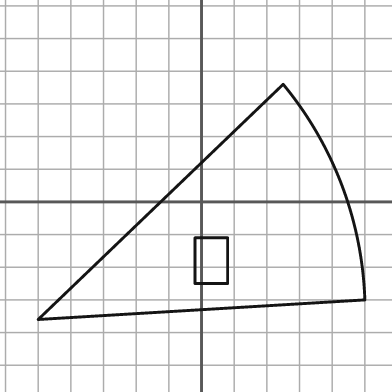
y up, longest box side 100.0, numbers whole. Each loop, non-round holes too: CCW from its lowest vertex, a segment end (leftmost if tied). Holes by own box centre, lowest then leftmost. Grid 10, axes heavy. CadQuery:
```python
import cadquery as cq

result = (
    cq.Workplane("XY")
    .moveTo(-50.0, -36.0)
    .lineTo(50.0, -30.0)
    .threePointArc((43.0, 5.0), (25.0, 36.0))
    .close()
    .moveTo(-2.0, -25.0)
    .lineTo(8.0, -25.0)
    .lineTo(8.0, -11.0)
    .lineTo(-2.0, -11.0)
    .close()
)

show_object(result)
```